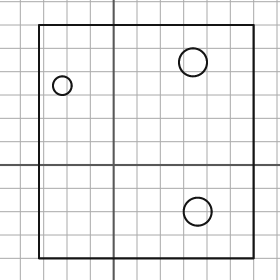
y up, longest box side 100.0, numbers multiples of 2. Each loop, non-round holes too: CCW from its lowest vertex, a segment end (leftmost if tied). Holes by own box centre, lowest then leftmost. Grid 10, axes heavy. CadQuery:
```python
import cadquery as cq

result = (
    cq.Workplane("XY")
    .moveTo(-32.0, -40.0)
    .lineTo(60.0, -40.0)
    .lineTo(60.0, 60.0)
    .lineTo(-32.0, 60.0)
    .close()
    .moveTo(36.0, -20.0)
    .circle(6.0)
    .moveTo(-22.0, 34.0)
    .circle(4.0)
    .moveTo(34.0, 44.0)
    .circle(6.0)
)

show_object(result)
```